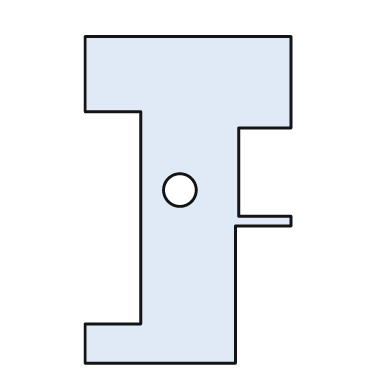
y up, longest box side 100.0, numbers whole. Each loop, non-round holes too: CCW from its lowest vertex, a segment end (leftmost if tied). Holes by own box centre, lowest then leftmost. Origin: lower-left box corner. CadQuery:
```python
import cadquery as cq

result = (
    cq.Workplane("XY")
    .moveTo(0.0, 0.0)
    .lineTo(46.0, 0.0)
    .lineTo(46.0, 42.0)
    .lineTo(63.0, 42.0)
    .lineTo(63.0, 45.0)
    .lineTo(47.0, 45.0)
    .lineTo(47.0, 72.0)
    .lineTo(63.0, 72.0)
    .lineTo(63.0, 100.0)
    .lineTo(0.0, 100.0)
    .lineTo(0.0, 77.0)
    .lineTo(17.0, 77.0)
    .lineTo(17.0, 12.0)
    .lineTo(0.0, 12.0)
    .close()
    .moveTo(29.0, 53.0)
    .circle(5.0)
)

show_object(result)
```